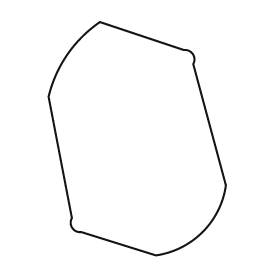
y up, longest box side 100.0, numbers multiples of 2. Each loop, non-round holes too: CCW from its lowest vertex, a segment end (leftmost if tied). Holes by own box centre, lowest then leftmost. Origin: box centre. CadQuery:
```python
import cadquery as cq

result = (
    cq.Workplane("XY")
    .moveTo(8.0, -50.0)
    .threePointArc((28.0, -40.0), (38.0, -20.0))
    .lineTo(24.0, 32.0)
    .threePointArc((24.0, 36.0), (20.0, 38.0))
    .lineTo(-16.0, 50.0)
    .threePointArc((-30.0, 36.0), (-38.0, 18.0))
    .lineTo(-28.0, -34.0)
    .threePointArc((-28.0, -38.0), (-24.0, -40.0))
    .close()
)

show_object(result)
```